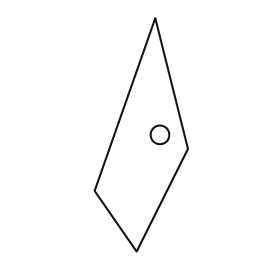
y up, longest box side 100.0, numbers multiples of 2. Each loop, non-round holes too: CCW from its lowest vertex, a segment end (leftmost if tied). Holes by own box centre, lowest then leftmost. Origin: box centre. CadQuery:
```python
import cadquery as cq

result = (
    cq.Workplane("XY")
    .moveTo(-2.0, -50.0)
    .lineTo(20.0, -6.0)
    .lineTo(6.0, 50.0)
    .lineTo(-20.0, -24.0)
    .close()
    .moveTo(8.0, 0.0)
    .circle(4.0)
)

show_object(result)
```